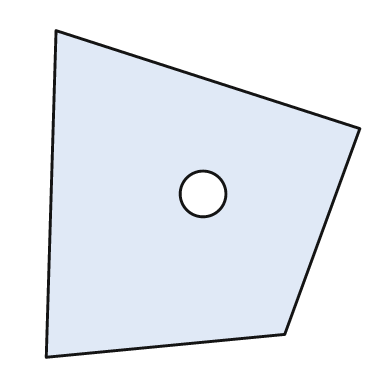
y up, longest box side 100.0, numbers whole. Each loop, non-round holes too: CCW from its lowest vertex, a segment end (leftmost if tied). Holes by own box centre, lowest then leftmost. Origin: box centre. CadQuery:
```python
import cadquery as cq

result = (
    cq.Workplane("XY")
    .moveTo(-48.0, -50.0)
    .lineTo(25.0, -43.0)
    .lineTo(48.0, 20.0)
    .lineTo(-45.0, 50.0)
    .close()
    .moveTo(0.0, 0.0)
    .circle(7.0)
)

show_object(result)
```